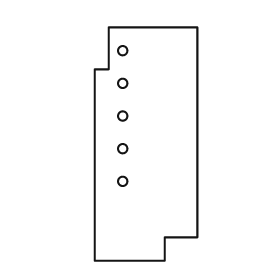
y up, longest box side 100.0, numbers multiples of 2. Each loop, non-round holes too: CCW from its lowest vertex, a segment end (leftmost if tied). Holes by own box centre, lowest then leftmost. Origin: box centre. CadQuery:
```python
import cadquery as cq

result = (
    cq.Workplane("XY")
    .moveTo(-22.0, -50.0)
    .lineTo(8.0, -50.0)
    .lineTo(8.0, -40.0)
    .lineTo(22.0, -40.0)
    .lineTo(22.0, 50.0)
    .lineTo(-16.0, 50.0)
    .lineTo(-16.0, 32.0)
    .lineTo(-22.0, 32.0)
    .close()
    .moveTo(-10.0, -16.0)
    .circle(2.0)
    .moveTo(-10.0, -2.0)
    .circle(2.0)
    .moveTo(-10.0, 12.0)
    .circle(2.0)
    .moveTo(-10.0, 26.0)
    .circle(2.0)
    .moveTo(-10.0, 40.0)
    .circle(2.0)
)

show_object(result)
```